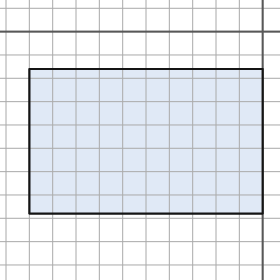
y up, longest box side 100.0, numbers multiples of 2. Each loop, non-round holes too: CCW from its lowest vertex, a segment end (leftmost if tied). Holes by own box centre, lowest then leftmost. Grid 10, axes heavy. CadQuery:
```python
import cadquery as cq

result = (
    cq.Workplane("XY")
    .moveTo(-100.0, -78.0)
    .lineTo(0.0, -78.0)
    .lineTo(0.0, -16.0)
    .lineTo(-100.0, -16.0)
    .close()
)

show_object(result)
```